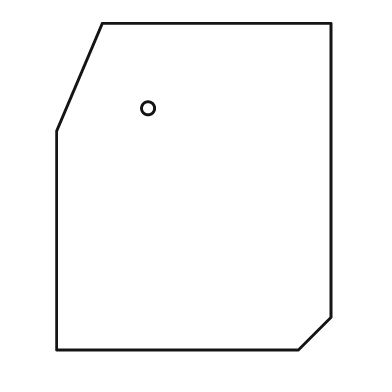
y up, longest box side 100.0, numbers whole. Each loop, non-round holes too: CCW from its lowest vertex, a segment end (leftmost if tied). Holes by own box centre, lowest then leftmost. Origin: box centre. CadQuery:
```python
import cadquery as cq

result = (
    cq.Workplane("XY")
    .moveTo(-42.0, -50.0)
    .lineTo(32.0, -50.0)
    .lineTo(42.0, -40.0)
    .lineTo(42.0, 50.0)
    .lineTo(-28.0, 50.0)
    .lineTo(-42.0, 17.0)
    .close()
    .moveTo(-14.0, 24.0)
    .circle(2.0)
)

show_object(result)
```